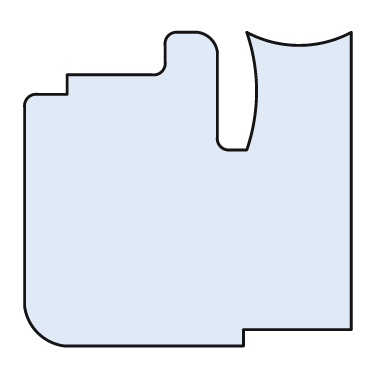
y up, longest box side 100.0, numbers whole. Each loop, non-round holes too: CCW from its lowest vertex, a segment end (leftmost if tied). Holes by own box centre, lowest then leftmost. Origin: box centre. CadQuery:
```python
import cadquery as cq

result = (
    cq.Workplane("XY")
    .moveTo(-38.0, -48.0)
    .lineTo(17.0, -48.0)
    .lineTo(17.0, -43.0)
    .lineTo(50.0, -43.0)
    .lineTo(50.0, 48.0)
    .threePointArc((34.0, 44.0), (18.0, 48.0))
    .threePointArc((21.0, 30.0), (18.0, 12.0))
    .lineTo(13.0, 12.0)
    .threePointArc((10.0, 13.0), (9.0, 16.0))
    .lineTo(9.0, 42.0)
    .threePointArc((7.0, 46.0), (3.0, 48.0))
    .lineTo(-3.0, 48.0)
    .threePointArc((-6.0, 47.0), (-7.0, 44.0))
    .lineTo(-7.0, 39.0)
    .threePointArc((-8.0, 36.0), (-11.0, 35.0))
    .lineTo(-37.0, 35.0)
    .lineTo(-37.0, 29.0)
    .lineTo(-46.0, 29.0)
    .threePointArc((-49.0, 28.0), (-50.0, 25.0))
    .lineTo(-50.0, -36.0)
    .threePointArc((-46.0, -44.0), (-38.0, -48.0))
    .close()
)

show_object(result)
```